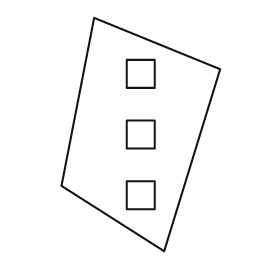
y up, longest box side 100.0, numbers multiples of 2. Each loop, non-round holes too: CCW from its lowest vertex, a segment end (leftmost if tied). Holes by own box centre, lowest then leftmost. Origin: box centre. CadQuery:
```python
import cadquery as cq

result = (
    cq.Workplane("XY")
    .moveTo(10.0, -50.0)
    .lineTo(34.0, 28.0)
    .lineTo(-20.0, 50.0)
    .lineTo(-34.0, -22.0)
    .close()
    .moveTo(-6.0, -32.0)
    .lineTo(6.0, -32.0)
    .lineTo(6.0, -20.0)
    .lineTo(-6.0, -20.0)
    .close()
    .moveTo(-6.0, -6.0)
    .lineTo(6.0, -6.0)
    .lineTo(6.0, 6.0)
    .lineTo(-6.0, 6.0)
    .close()
    .moveTo(-6.0, 20.0)
    .lineTo(6.0, 20.0)
    .lineTo(6.0, 32.0)
    .lineTo(-6.0, 32.0)
    .close()
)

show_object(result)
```